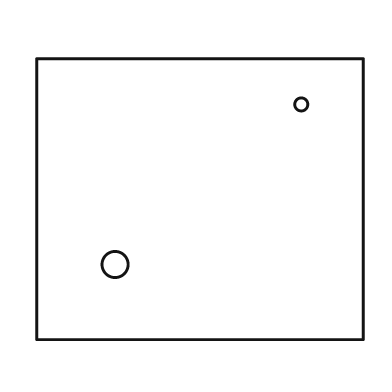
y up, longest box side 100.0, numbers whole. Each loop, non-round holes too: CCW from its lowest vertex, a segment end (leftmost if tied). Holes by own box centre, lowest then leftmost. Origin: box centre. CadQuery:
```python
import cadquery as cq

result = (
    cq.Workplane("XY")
    .moveTo(-50.0, -43.0)
    .lineTo(50.0, -43.0)
    .lineTo(50.0, 43.0)
    .lineTo(-50.0, 43.0)
    .close()
    .moveTo(-26.0, -20.0)
    .circle(4.0)
    .moveTo(31.0, 29.0)
    .circle(2.0)
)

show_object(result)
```